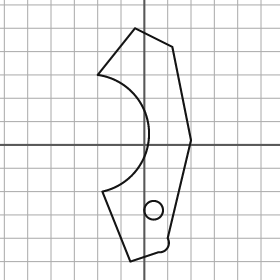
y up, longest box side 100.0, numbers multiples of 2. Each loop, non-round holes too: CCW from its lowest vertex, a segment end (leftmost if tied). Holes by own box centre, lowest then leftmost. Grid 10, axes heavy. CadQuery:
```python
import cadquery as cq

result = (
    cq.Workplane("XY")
    .moveTo(-6.0, -50.0)
    .lineTo(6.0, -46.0)
    .threePointArc((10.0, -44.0), (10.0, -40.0))
    .lineTo(20.0, 2.0)
    .lineTo(12.0, 42.0)
    .lineTo(-4.0, 50.0)
    .lineTo(-20.0, 30.0)
    .threePointArc((2.0, 6.0), (-18.0, -20.0))
    .close()
    .moveTo(4.0, -28.0)
    .circle(4.0)
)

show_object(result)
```